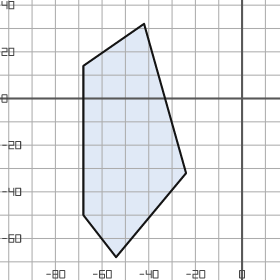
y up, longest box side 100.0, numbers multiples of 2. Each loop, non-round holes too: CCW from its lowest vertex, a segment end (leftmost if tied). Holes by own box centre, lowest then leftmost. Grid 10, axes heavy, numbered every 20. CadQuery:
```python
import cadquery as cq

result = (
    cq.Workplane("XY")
    .moveTo(-54.0, -68.0)
    .lineTo(-24.0, -32.0)
    .lineTo(-42.0, 32.0)
    .lineTo(-68.0, 14.0)
    .lineTo(-68.0, -50.0)
    .close()
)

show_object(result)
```